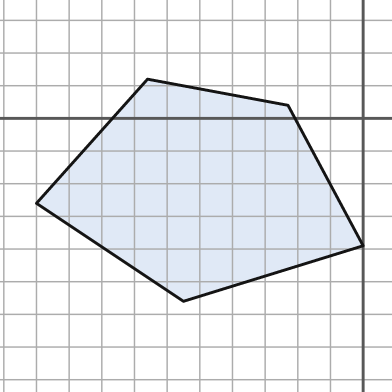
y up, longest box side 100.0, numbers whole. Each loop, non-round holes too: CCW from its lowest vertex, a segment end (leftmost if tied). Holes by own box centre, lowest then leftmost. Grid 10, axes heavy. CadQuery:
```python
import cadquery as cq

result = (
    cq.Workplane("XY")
    .moveTo(-55.0, -56.0)
    .lineTo(0.0, -39.0)
    .lineTo(-23.0, 4.0)
    .lineTo(-66.0, 12.0)
    .lineTo(-100.0, -26.0)
    .close()
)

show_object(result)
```